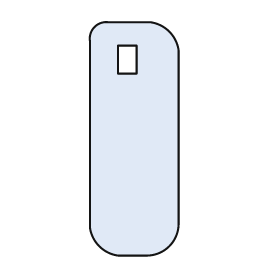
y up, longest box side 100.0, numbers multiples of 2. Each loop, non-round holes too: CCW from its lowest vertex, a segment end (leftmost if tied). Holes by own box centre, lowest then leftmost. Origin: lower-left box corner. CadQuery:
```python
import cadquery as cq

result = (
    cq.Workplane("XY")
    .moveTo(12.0, 0.0)
    .lineTo(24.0, 0.0)
    .threePointArc((34.0, 4.0), (38.0, 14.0))
    .lineTo(38.0, 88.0)
    .threePointArc((34.0, 96.0), (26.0, 100.0))
    .lineTo(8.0, 100.0)
    .threePointArc((2.0, 98.0), (0.0, 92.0))
    .lineTo(0.0, 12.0)
    .threePointArc((4.0, 4.0), (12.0, 0.0))
    .close()
    .moveTo(12.0, 78.0)
    .lineTo(20.0, 78.0)
    .lineTo(20.0, 90.0)
    .lineTo(12.0, 90.0)
    .close()
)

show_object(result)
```